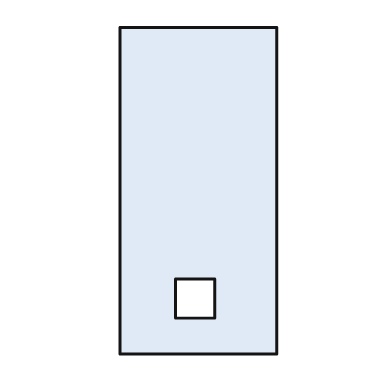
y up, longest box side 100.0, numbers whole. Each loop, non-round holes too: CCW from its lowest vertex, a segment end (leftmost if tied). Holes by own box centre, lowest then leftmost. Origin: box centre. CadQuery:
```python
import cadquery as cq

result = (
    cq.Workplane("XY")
    .moveTo(-24.0, -50.0)
    .lineTo(24.0, -50.0)
    .lineTo(24.0, 50.0)
    .lineTo(-24.0, 50.0)
    .close()
    .moveTo(-7.0, -39.0)
    .lineTo(5.0, -39.0)
    .lineTo(5.0, -27.0)
    .lineTo(-7.0, -27.0)
    .close()
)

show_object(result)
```